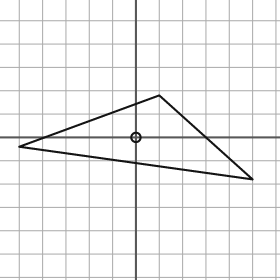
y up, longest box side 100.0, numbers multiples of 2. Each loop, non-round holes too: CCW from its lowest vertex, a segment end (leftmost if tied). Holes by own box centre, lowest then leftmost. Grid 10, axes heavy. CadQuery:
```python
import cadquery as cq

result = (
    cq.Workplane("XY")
    .moveTo(50.0, -18.0)
    .lineTo(10.0, 18.0)
    .lineTo(-50.0, -4.0)
    .close()
    .moveTo(0.0, 0.0)
    .circle(2.0)
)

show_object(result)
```